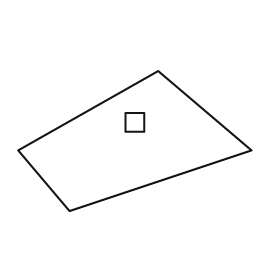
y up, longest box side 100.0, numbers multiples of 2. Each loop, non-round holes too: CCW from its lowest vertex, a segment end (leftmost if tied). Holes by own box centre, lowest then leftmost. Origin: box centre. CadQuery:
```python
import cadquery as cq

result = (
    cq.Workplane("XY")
    .moveTo(-28.0, -30.0)
    .lineTo(50.0, -4.0)
    .lineTo(10.0, 30.0)
    .lineTo(-50.0, -4.0)
    .close()
    .moveTo(-4.0, 4.0)
    .lineTo(4.0, 4.0)
    .lineTo(4.0, 12.0)
    .lineTo(-4.0, 12.0)
    .close()
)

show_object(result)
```